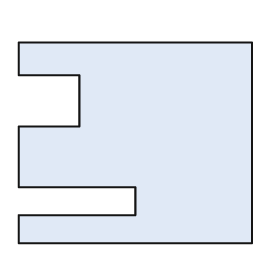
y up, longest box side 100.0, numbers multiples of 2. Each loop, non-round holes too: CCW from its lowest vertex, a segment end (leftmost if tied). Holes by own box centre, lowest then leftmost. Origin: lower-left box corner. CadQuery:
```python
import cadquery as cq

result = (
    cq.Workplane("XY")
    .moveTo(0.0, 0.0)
    .lineTo(100.0, 0.0)
    .lineTo(100.0, 86.0)
    .lineTo(0.0, 86.0)
    .lineTo(0.0, 72.0)
    .lineTo(26.0, 72.0)
    .lineTo(26.0, 50.0)
    .lineTo(0.0, 50.0)
    .lineTo(0.0, 24.0)
    .lineTo(50.0, 24.0)
    .lineTo(50.0, 12.0)
    .lineTo(0.0, 12.0)
    .close()
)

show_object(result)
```